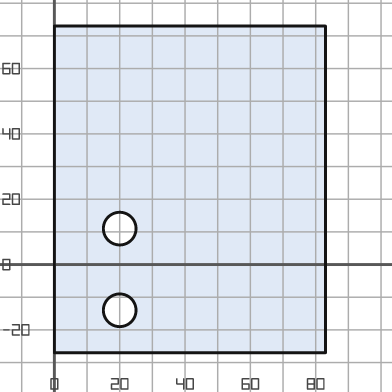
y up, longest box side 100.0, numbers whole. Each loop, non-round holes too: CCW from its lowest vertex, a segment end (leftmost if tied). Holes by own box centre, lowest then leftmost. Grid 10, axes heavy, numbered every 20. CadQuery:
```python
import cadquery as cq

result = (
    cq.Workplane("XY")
    .moveTo(0.0, -27.0)
    .lineTo(83.0, -27.0)
    .lineTo(83.0, 73.0)
    .lineTo(0.0, 73.0)
    .close()
    .moveTo(20.0, -14.0)
    .circle(5.0)
    .moveTo(20.0, 11.0)
    .circle(5.0)
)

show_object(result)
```